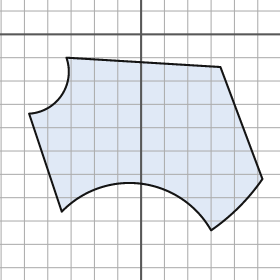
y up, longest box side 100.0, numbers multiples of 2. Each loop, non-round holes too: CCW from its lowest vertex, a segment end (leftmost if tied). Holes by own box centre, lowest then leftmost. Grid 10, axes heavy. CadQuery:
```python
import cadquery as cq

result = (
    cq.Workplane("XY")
    .moveTo(30.0, -84.0)
    .threePointArc((42.0, -74.0), (52.0, -62.0))
    .lineTo(34.0, -14.0)
    .lineTo(-32.0, -10.0)
    .threePointArc((-34.0, -26.0), (-48.0, -34.0))
    .lineTo(-34.0, -76.0)
    .threePointArc((0.0, -64.0), (30.0, -84.0))
    .close()
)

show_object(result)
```